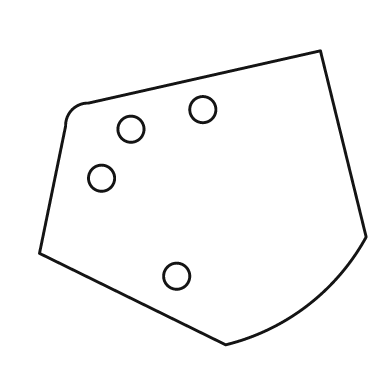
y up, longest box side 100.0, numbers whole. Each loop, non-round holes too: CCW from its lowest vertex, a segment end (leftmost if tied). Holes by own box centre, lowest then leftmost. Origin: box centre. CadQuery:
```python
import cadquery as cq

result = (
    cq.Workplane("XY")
    .moveTo(7.0, -45.0)
    .threePointArc((32.0, -33.0), (50.0, -12.0))
    .lineTo(36.0, 45.0)
    .lineTo(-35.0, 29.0)
    .threePointArc((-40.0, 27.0), (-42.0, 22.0))
    .lineTo(-50.0, -17.0)
    .close()
    .moveTo(-8.0, -24.0)
    .circle(4.0)
    .moveTo(-31.0, 6.0)
    .circle(4.0)
    .moveTo(-22.0, 21.0)
    .circle(4.0)
    .moveTo(0.0, 27.0)
    .circle(4.0)
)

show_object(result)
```